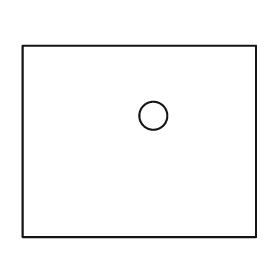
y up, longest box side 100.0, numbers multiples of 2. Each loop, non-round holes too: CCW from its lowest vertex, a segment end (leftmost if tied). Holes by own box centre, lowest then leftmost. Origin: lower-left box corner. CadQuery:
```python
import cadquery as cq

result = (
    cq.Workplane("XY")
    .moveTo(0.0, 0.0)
    .lineTo(100.0, 0.0)
    .lineTo(100.0, 82.0)
    .lineTo(0.0, 82.0)
    .close()
    .moveTo(56.0, 52.0)
    .circle(6.0)
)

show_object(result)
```